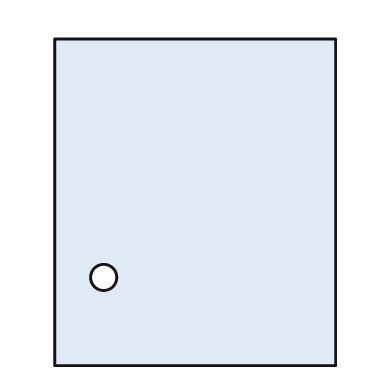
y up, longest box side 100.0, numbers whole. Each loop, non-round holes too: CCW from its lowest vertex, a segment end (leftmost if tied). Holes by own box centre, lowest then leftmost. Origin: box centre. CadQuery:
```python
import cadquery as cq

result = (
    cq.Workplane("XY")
    .moveTo(-43.0, -50.0)
    .lineTo(43.0, -50.0)
    .lineTo(43.0, 50.0)
    .lineTo(-43.0, 50.0)
    .close()
    .moveTo(-28.0, -23.0)
    .circle(4.0)
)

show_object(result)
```